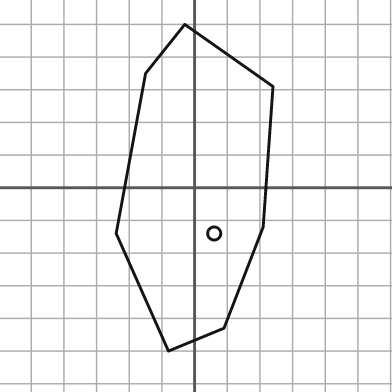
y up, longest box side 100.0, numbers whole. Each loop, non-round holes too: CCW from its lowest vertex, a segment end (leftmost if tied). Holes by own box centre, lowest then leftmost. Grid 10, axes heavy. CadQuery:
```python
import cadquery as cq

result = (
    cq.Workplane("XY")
    .moveTo(-8.0, -50.0)
    .lineTo(9.0, -43.0)
    .lineTo(21.0, -12.0)
    .lineTo(24.0, 31.0)
    .lineTo(-3.0, 50.0)
    .lineTo(-15.0, 35.0)
    .lineTo(-24.0, -14.0)
    .close()
    .moveTo(6.0, -14.0)
    .circle(2.0)
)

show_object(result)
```